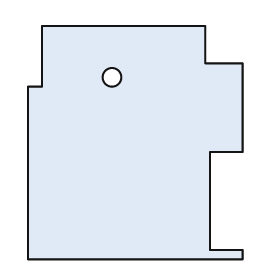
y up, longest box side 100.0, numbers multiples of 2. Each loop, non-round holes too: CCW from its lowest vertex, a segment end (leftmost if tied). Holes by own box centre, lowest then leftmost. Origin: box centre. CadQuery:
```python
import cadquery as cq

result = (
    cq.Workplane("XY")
    .moveTo(-46.0, -50.0)
    .lineTo(46.0, -50.0)
    .lineTo(46.0, -46.0)
    .lineTo(32.0, -46.0)
    .lineTo(32.0, -4.0)
    .lineTo(46.0, -4.0)
    .lineTo(46.0, 34.0)
    .lineTo(30.0, 34.0)
    .lineTo(30.0, 50.0)
    .lineTo(-40.0, 50.0)
    .lineTo(-40.0, 24.0)
    .lineTo(-46.0, 24.0)
    .close()
    .moveTo(-10.0, 28.0)
    .circle(4.0)
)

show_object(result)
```